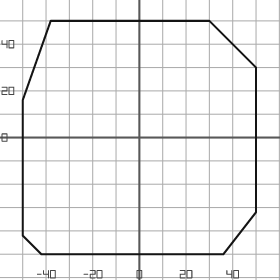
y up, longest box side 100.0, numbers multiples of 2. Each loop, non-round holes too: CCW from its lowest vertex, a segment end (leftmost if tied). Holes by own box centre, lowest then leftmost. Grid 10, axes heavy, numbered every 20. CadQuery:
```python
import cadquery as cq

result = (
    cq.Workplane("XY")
    .moveTo(-42.0, -50.0)
    .lineTo(36.0, -50.0)
    .lineTo(50.0, -32.0)
    .lineTo(50.0, 30.0)
    .lineTo(30.0, 50.0)
    .lineTo(-38.0, 50.0)
    .lineTo(-50.0, 16.0)
    .lineTo(-50.0, -42.0)
    .close()
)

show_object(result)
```